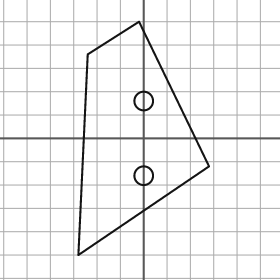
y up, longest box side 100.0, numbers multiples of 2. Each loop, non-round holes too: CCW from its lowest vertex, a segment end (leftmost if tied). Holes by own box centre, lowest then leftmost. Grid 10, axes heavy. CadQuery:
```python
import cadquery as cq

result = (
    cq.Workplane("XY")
    .moveTo(-28.0, -50.0)
    .lineTo(28.0, -12.0)
    .lineTo(-2.0, 50.0)
    .lineTo(-24.0, 36.0)
    .close()
    .moveTo(0.0, -16.0)
    .circle(4.0)
    .moveTo(0.0, 16.0)
    .circle(4.0)
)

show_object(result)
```